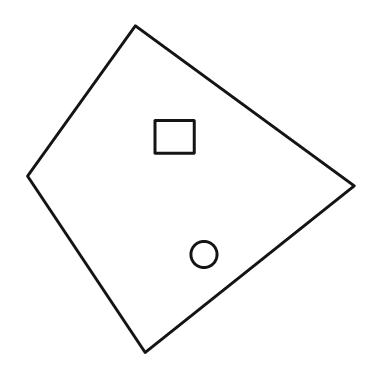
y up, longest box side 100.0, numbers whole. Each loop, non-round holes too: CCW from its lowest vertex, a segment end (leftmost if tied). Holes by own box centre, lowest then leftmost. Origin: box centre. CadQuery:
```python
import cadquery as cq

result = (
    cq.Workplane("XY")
    .moveTo(-14.0, -50.0)
    .lineTo(50.0, 1.0)
    .lineTo(-17.0, 50.0)
    .lineTo(-50.0, 4.0)
    .close()
    .moveTo(4.0, -20.0)
    .circle(4.0)
    .moveTo(-11.0, 11.0)
    .lineTo(1.0, 11.0)
    .lineTo(1.0, 21.0)
    .lineTo(-11.0, 21.0)
    .close()
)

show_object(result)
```